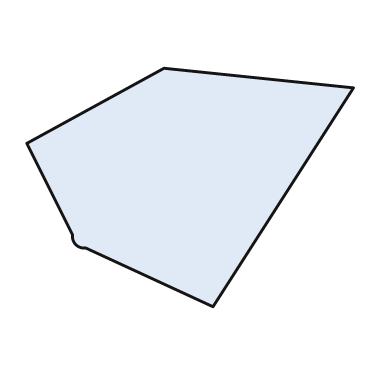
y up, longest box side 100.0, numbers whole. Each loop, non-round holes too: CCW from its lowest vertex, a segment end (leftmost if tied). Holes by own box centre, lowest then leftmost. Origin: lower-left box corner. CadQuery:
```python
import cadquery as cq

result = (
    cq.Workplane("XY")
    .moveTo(57.0, 0.0)
    .lineTo(100.0, 67.0)
    .lineTo(42.0, 73.0)
    .lineTo(0.0, 50.0)
    .lineTo(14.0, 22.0)
    .threePointArc((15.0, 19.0), (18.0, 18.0))
    .close()
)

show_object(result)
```